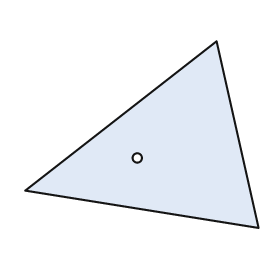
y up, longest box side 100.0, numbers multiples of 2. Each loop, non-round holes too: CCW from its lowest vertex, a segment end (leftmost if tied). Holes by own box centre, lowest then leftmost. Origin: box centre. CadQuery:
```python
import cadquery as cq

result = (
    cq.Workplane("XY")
    .moveTo(50.0, -40.0)
    .lineTo(32.0, 40.0)
    .lineTo(-50.0, -24.0)
    .close()
    .moveTo(-2.0, -10.0)
    .circle(2.0)
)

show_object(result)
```